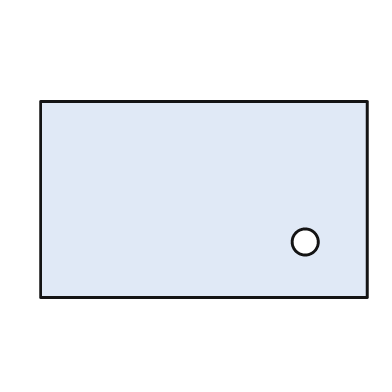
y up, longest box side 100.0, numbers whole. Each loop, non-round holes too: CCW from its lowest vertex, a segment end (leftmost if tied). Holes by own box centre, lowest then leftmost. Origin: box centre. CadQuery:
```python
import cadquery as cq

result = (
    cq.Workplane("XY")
    .moveTo(-50.0, -30.0)
    .lineTo(50.0, -30.0)
    .lineTo(50.0, 30.0)
    .lineTo(-50.0, 30.0)
    .close()
    .moveTo(31.0, -13.0)
    .circle(4.0)
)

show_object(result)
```